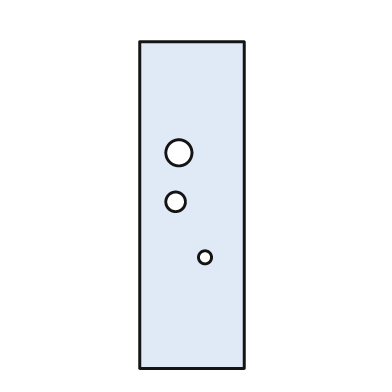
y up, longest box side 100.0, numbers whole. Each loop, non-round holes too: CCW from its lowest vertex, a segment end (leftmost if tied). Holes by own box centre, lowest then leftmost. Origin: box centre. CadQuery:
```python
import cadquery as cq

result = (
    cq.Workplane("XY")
    .moveTo(-16.0, -50.0)
    .lineTo(16.0, -50.0)
    .lineTo(16.0, 50.0)
    .lineTo(-16.0, 50.0)
    .close()
    .moveTo(4.0, -16.0)
    .circle(2.0)
    .moveTo(-5.0, 1.0)
    .circle(3.0)
    .moveTo(-4.0, 16.0)
    .circle(4.0)
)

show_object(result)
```